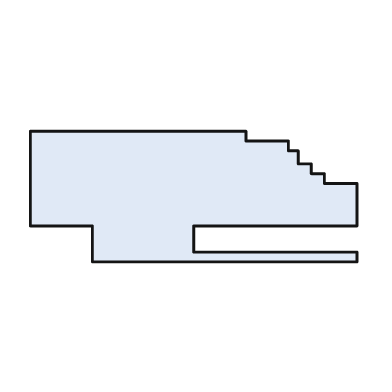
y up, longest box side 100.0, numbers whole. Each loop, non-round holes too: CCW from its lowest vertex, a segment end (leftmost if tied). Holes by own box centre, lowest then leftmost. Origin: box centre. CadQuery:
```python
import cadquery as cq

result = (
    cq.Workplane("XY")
    .moveTo(-31.0, -20.0)
    .lineTo(50.0, -20.0)
    .lineTo(50.0, -17.0)
    .lineTo(0.0, -17.0)
    .lineTo(0.0, -9.0)
    .lineTo(50.0, -9.0)
    .lineTo(50.0, 4.0)
    .lineTo(40.0, 4.0)
    .lineTo(40.0, 7.0)
    .lineTo(36.0, 7.0)
    .lineTo(36.0, 10.0)
    .lineTo(32.0, 10.0)
    .lineTo(32.0, 14.0)
    .lineTo(29.0, 14.0)
    .lineTo(29.0, 17.0)
    .lineTo(16.0, 17.0)
    .lineTo(16.0, 20.0)
    .lineTo(-50.0, 20.0)
    .lineTo(-50.0, -9.0)
    .lineTo(-31.0, -9.0)
    .close()
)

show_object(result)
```